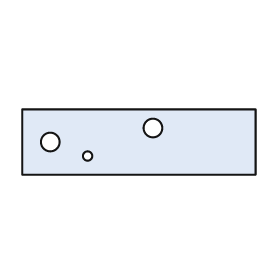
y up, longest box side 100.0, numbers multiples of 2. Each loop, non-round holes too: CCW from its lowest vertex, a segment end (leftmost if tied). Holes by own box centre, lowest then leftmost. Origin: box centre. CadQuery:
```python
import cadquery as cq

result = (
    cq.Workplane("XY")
    .moveTo(-50.0, -14.0)
    .lineTo(50.0, -14.0)
    .lineTo(50.0, 14.0)
    .lineTo(-50.0, 14.0)
    .close()
    .moveTo(-22.0, -6.0)
    .circle(2.0)
    .moveTo(-38.0, 0.0)
    .circle(4.0)
    .moveTo(6.0, 6.0)
    .circle(4.0)
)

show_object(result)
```